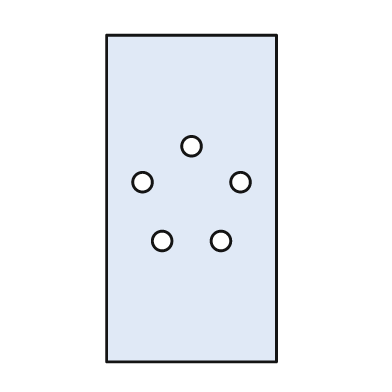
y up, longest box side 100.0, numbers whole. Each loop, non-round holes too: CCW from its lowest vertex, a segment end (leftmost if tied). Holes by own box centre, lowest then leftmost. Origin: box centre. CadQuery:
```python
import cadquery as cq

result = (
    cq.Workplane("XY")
    .moveTo(-26.0, -50.0)
    .lineTo(26.0, -50.0)
    .lineTo(26.0, 50.0)
    .lineTo(-26.0, 50.0)
    .close()
    .moveTo(-9.0, -13.0)
    .circle(3.0)
    .moveTo(9.0, -13.0)
    .circle(3.0)
    .moveTo(-15.0, 5.0)
    .circle(3.0)
    .moveTo(15.0, 5.0)
    .circle(3.0)
    .moveTo(0.0, 16.0)
    .circle(3.0)
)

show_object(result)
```